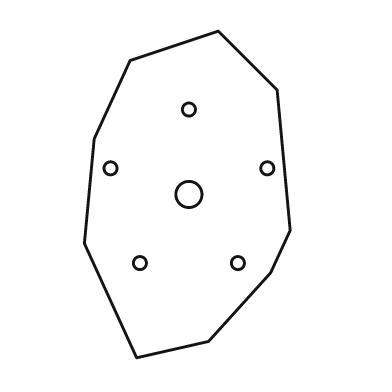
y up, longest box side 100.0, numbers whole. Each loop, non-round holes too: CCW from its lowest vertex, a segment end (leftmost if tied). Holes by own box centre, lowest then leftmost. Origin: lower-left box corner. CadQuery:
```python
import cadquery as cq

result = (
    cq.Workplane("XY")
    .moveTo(16.0, 0.0)
    .lineTo(38.0, 5.0)
    .lineTo(57.0, 26.0)
    .lineTo(63.0, 39.0)
    .lineTo(59.0, 82.0)
    .lineTo(41.0, 100.0)
    .lineTo(14.0, 91.0)
    .lineTo(3.0, 67.0)
    .lineTo(0.0, 35.0)
    .close()
    .moveTo(17.0, 29.0)
    .circle(2.0)
    .moveTo(47.0, 29.0)
    .circle(2.0)
    .moveTo(32.0, 50.0)
    .circle(4.0)
    .moveTo(8.0, 58.0)
    .circle(2.0)
    .moveTo(56.0, 58.0)
    .circle(2.0)
    .moveTo(32.0, 76.0)
    .circle(2.0)
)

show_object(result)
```